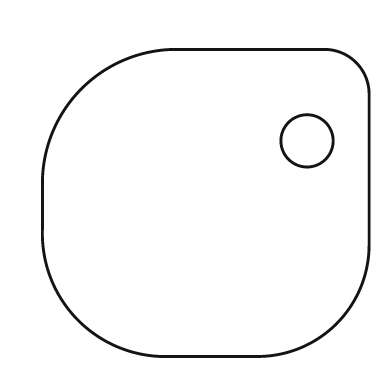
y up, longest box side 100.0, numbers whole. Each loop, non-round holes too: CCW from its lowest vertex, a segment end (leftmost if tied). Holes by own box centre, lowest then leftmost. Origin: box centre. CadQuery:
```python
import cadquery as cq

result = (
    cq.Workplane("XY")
    .moveTo(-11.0, -47.0)
    .lineTo(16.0, -47.0)
    .threePointArc((40.0, -37.0), (50.0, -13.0))
    .lineTo(50.0, 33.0)
    .threePointArc((46.0, 43.0), (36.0, 47.0))
    .lineTo(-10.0, 47.0)
    .threePointArc((-38.0, 35.0), (-50.0, 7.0))
    .lineTo(-50.0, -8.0)
    .threePointArc((-39.0, -36.0), (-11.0, -47.0))
    .close()
    .moveTo(31.0, 19.0)
    .circle(8.0)
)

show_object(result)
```